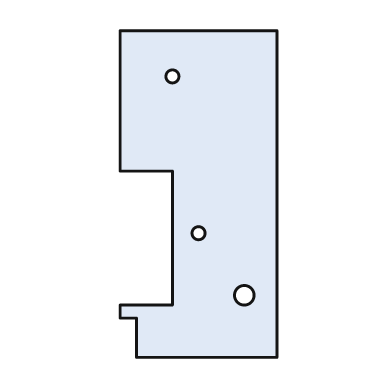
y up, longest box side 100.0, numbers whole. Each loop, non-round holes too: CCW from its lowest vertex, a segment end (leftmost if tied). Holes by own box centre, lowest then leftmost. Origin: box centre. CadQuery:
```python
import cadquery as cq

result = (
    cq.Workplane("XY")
    .moveTo(-19.0, -50.0)
    .lineTo(24.0, -50.0)
    .lineTo(24.0, 50.0)
    .lineTo(-24.0, 50.0)
    .lineTo(-24.0, 7.0)
    .lineTo(-8.0, 7.0)
    .lineTo(-8.0, -34.0)
    .lineTo(-24.0, -34.0)
    .lineTo(-24.0, -38.0)
    .lineTo(-19.0, -38.0)
    .close()
    .moveTo(14.0, -31.0)
    .circle(3.0)
    .moveTo(0.0, -12.0)
    .circle(2.0)
    .moveTo(-8.0, 36.0)
    .circle(2.0)
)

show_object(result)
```